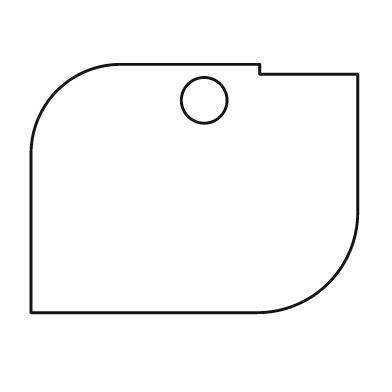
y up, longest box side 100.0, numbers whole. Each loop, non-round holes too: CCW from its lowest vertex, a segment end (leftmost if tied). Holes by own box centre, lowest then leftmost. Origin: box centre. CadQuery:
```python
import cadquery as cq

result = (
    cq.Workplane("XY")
    .moveTo(-50.0, -38.0)
    .lineTo(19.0, -38.0)
    .threePointArc((41.0, -29.0), (50.0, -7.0))
    .lineTo(50.0, 35.0)
    .lineTo(20.0, 35.0)
    .lineTo(20.0, 38.0)
    .lineTo(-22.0, 38.0)
    .threePointArc((-42.0, 30.0), (-50.0, 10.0))
    .close()
    .moveTo(3.0, 27.0)
    .circle(7.0)
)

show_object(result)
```